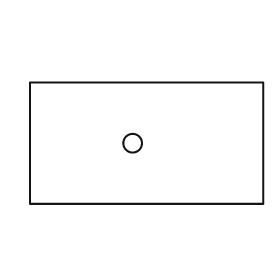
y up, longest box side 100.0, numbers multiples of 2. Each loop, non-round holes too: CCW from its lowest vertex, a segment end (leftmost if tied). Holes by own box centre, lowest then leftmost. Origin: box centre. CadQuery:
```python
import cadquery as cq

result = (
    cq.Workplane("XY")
    .moveTo(-50.0, -26.0)
    .lineTo(50.0, -26.0)
    .lineTo(50.0, 26.0)
    .lineTo(-50.0, 26.0)
    .close()
    .moveTo(-6.0, 0.0)
    .circle(4.0)
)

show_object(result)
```